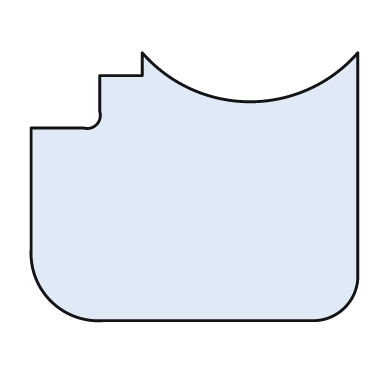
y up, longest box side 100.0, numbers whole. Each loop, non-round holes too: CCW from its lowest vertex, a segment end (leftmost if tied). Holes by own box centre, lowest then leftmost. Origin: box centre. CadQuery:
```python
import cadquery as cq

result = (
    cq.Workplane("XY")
    .moveTo(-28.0, -41.0)
    .lineTo(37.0, -41.0)
    .threePointArc((46.0, -37.0), (50.0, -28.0))
    .lineTo(50.0, 41.0)
    .threePointArc((17.0, 26.0), (-16.0, 41.0))
    .lineTo(-16.0, 34.0)
    .lineTo(-29.0, 34.0)
    .lineTo(-29.0, 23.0)
    .threePointArc((-30.0, 19.0), (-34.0, 18.0))
    .lineTo(-50.0, 18.0)
    .lineTo(-50.0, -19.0)
    .threePointArc((-44.0, -35.0), (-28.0, -41.0))
    .close()
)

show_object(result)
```